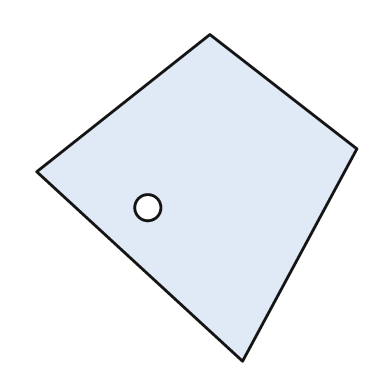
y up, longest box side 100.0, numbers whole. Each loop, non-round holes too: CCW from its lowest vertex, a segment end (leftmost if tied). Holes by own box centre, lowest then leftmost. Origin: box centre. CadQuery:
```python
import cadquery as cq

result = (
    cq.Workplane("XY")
    .moveTo(14.0, -50.0)
    .lineTo(49.0, 15.0)
    .lineTo(4.0, 50.0)
    .lineTo(-49.0, 8.0)
    .close()
    .moveTo(-15.0, -3.0)
    .circle(4.0)
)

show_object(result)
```